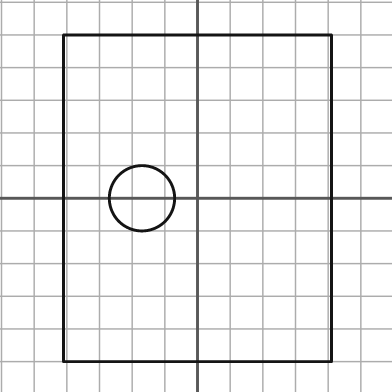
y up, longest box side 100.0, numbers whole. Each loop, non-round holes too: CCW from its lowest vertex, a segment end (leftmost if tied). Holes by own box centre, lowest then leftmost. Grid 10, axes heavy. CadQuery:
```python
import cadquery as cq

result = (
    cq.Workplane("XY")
    .moveTo(-41.0, -50.0)
    .lineTo(41.0, -50.0)
    .lineTo(41.0, 50.0)
    .lineTo(-41.0, 50.0)
    .close()
    .moveTo(-17.0, 0.0)
    .circle(10.0)
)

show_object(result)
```